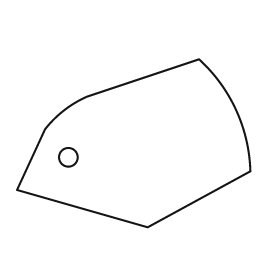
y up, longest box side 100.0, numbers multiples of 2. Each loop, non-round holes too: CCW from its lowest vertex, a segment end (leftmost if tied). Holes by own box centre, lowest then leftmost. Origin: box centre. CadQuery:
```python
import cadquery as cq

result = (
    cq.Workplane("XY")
    .moveTo(6.0, -36.0)
    .lineTo(50.0, -12.0)
    .threePointArc((44.0, 14.0), (28.0, 36.0))
    .lineTo(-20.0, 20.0)
    .threePointArc((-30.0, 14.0), (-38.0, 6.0))
    .lineTo(-50.0, -20.0)
    .close()
    .moveTo(-28.0, -6.0)
    .circle(4.0)
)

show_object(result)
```